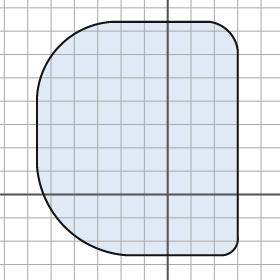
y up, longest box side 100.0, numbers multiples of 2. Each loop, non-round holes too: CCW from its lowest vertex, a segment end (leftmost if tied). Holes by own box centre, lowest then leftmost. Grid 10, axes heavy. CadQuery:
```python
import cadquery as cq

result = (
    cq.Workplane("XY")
    .moveTo(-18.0, -26.0)
    .lineTo(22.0, -26.0)
    .threePointArc((28.0, -24.0), (30.0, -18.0))
    .lineTo(30.0, 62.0)
    .threePointArc((26.0, 70.0), (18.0, 74.0))
    .lineTo(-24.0, 74.0)
    .threePointArc((-46.0, 64.0), (-56.0, 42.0))
    .lineTo(-56.0, 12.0)
    .threePointArc((-44.0, -14.0), (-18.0, -26.0))
    .close()
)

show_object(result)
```